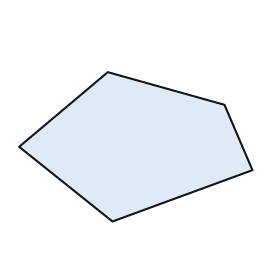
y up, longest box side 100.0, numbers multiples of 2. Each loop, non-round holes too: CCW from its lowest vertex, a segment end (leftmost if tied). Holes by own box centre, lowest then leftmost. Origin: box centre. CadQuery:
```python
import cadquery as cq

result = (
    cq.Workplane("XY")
    .moveTo(-10.0, -32.0)
    .lineTo(50.0, -10.0)
    .lineTo(38.0, 18.0)
    .lineTo(-12.0, 32.0)
    .lineTo(-50.0, 0.0)
    .close()
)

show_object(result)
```